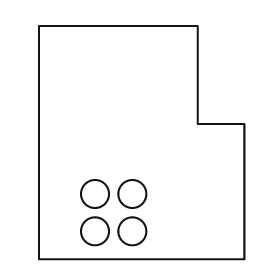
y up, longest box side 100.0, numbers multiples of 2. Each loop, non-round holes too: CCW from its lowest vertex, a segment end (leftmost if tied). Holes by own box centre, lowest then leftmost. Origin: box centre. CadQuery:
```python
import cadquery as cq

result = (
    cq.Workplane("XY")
    .moveTo(-44.0, -50.0)
    .lineTo(44.0, -50.0)
    .lineTo(44.0, 8.0)
    .lineTo(24.0, 8.0)
    .lineTo(24.0, 50.0)
    .lineTo(-44.0, 50.0)
    .close()
    .moveTo(-20.0, -38.0)
    .circle(6.0)
    .moveTo(-4.0, -38.0)
    .circle(6.0)
    .moveTo(-20.0, -22.0)
    .circle(6.0)
    .moveTo(-4.0, -22.0)
    .circle(6.0)
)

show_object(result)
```